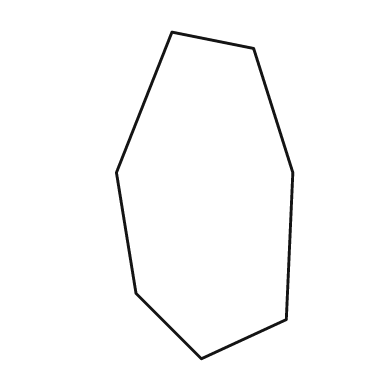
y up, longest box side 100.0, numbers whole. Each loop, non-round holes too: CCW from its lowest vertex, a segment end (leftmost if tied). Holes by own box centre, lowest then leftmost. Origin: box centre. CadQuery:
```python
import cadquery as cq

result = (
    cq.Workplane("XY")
    .moveTo(-1.0, -50.0)
    .lineTo(25.0, -38.0)
    .lineTo(27.0, 7.0)
    .lineTo(15.0, 45.0)
    .lineTo(-10.0, 50.0)
    .lineTo(-27.0, 7.0)
    .lineTo(-21.0, -30.0)
    .close()
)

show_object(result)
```